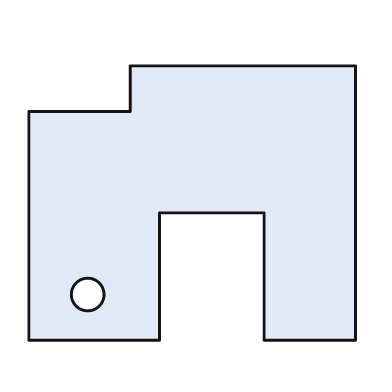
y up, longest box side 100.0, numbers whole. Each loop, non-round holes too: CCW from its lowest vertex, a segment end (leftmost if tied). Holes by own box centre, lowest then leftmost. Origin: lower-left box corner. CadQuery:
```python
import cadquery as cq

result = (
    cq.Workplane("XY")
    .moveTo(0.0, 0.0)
    .lineTo(40.0, 0.0)
    .lineTo(40.0, 39.0)
    .lineTo(72.0, 39.0)
    .lineTo(72.0, 0.0)
    .lineTo(100.0, 0.0)
    .lineTo(100.0, 84.0)
    .lineTo(31.0, 84.0)
    .lineTo(31.0, 70.0)
    .lineTo(0.0, 70.0)
    .close()
    .moveTo(18.0, 14.0)
    .circle(5.0)
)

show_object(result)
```